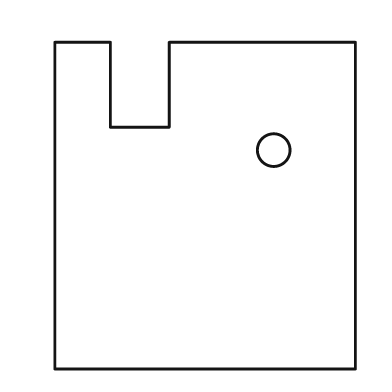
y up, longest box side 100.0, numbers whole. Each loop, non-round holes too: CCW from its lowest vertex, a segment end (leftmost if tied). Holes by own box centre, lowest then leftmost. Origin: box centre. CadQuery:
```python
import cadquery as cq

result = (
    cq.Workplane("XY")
    .moveTo(-46.0, -50.0)
    .lineTo(46.0, -50.0)
    .lineTo(46.0, 50.0)
    .lineTo(-11.0, 50.0)
    .lineTo(-11.0, 24.0)
    .lineTo(-29.0, 24.0)
    .lineTo(-29.0, 50.0)
    .lineTo(-46.0, 50.0)
    .close()
    .moveTo(21.0, 17.0)
    .circle(5.0)
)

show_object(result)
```